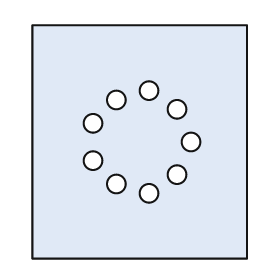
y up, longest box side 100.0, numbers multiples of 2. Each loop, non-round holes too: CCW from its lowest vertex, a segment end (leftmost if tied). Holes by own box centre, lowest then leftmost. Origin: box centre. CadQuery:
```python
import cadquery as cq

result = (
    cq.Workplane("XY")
    .moveTo(-46.0, -50.0)
    .lineTo(46.0, -50.0)
    .lineTo(46.0, 50.0)
    .lineTo(-46.0, 50.0)
    .close()
    .moveTo(4.0, -22.0)
    .circle(4.0)
    .moveTo(-10.0, -18.0)
    .circle(4.0)
    .moveTo(16.0, -14.0)
    .circle(4.0)
    .moveTo(-20.0, -8.0)
    .circle(4.0)
    .moveTo(22.0, 0.0)
    .circle(4.0)
    .moveTo(-20.0, 8.0)
    .circle(4.0)
    .moveTo(16.0, 14.0)
    .circle(4.0)
    .moveTo(-10.0, 18.0)
    .circle(4.0)
    .moveTo(4.0, 22.0)
    .circle(4.0)
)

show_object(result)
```